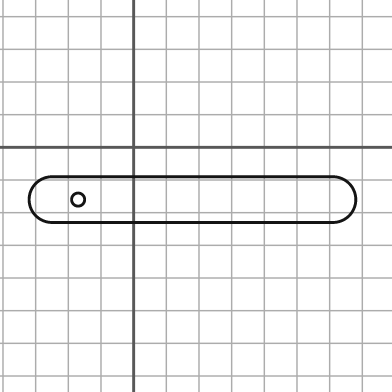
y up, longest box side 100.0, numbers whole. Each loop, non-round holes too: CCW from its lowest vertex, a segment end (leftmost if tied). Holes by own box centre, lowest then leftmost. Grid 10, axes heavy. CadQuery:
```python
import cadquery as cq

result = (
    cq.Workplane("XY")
    .moveTo(-25.0, -23.0)
    .lineTo(61.0, -23.0)
    .threePointArc((68.0, -16.0), (61.0, -9.0))
    .lineTo(-25.0, -9.0)
    .threePointArc((-32.0, -16.0), (-25.0, -23.0))
    .close()
    .moveTo(-17.0, -16.0)
    .circle(2.0)
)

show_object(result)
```